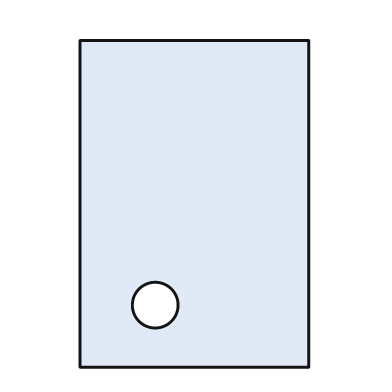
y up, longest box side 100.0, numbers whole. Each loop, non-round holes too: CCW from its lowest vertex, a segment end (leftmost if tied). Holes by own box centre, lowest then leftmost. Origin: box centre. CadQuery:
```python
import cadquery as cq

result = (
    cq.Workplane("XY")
    .moveTo(-35.0, -50.0)
    .lineTo(35.0, -50.0)
    .lineTo(35.0, 50.0)
    .lineTo(-35.0, 50.0)
    .close()
    .moveTo(-12.0, -31.0)
    .circle(7.0)
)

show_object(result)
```